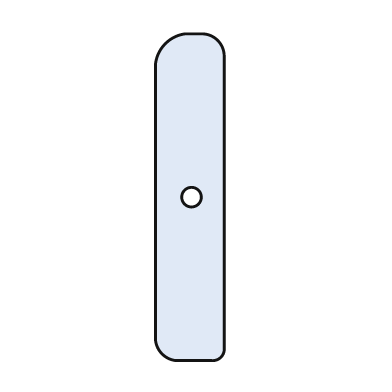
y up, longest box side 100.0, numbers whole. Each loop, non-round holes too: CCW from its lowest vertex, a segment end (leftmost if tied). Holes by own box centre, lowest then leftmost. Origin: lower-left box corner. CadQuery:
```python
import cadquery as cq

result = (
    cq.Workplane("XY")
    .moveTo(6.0, 0.0)
    .lineTo(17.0, 0.0)
    .threePointArc((20.0, 1.0), (21.0, 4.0))
    .lineTo(21.0, 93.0)
    .threePointArc((19.0, 98.0), (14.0, 100.0))
    .lineTo(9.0, 100.0)
    .threePointArc((3.0, 97.0), (0.0, 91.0))
    .lineTo(0.0, 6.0)
    .threePointArc((2.0, 2.0), (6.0, 0.0))
    .close()
    .moveTo(11.0, 50.0)
    .circle(3.0)
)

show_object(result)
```